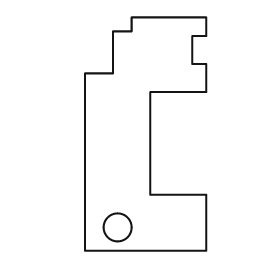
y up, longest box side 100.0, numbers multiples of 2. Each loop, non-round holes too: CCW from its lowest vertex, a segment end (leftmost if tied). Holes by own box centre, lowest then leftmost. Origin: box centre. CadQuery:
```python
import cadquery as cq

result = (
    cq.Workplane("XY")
    .moveTo(-26.0, -50.0)
    .lineTo(26.0, -50.0)
    .lineTo(26.0, -26.0)
    .lineTo(2.0, -26.0)
    .lineTo(2.0, 18.0)
    .lineTo(26.0, 18.0)
    .lineTo(26.0, 30.0)
    .lineTo(20.0, 30.0)
    .lineTo(20.0, 42.0)
    .lineTo(26.0, 42.0)
    .lineTo(26.0, 50.0)
    .lineTo(-6.0, 50.0)
    .lineTo(-6.0, 44.0)
    .lineTo(-14.0, 44.0)
    .lineTo(-14.0, 26.0)
    .lineTo(-26.0, 26.0)
    .close()
    .moveTo(-12.0, -40.0)
    .circle(6.0)
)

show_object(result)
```